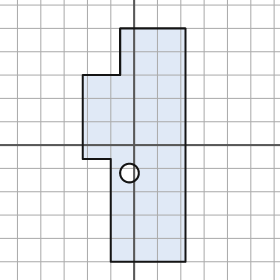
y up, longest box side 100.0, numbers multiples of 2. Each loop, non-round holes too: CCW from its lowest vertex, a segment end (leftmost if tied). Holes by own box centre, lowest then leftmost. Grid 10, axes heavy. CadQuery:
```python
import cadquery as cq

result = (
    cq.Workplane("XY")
    .moveTo(-10.0, -50.0)
    .lineTo(22.0, -50.0)
    .lineTo(22.0, 50.0)
    .lineTo(-6.0, 50.0)
    .lineTo(-6.0, 30.0)
    .lineTo(-22.0, 30.0)
    .lineTo(-22.0, -6.0)
    .lineTo(-10.0, -6.0)
    .close()
    .moveTo(-2.0, -12.0)
    .circle(4.0)
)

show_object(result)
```